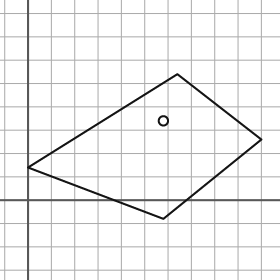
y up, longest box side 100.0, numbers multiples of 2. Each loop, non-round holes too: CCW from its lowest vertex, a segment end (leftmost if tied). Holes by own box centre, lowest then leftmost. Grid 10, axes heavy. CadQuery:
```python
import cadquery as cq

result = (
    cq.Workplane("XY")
    .moveTo(58.0, -8.0)
    .lineTo(100.0, 26.0)
    .lineTo(64.0, 54.0)
    .lineTo(0.0, 14.0)
    .close()
    .moveTo(58.0, 34.0)
    .circle(2.0)
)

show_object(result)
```